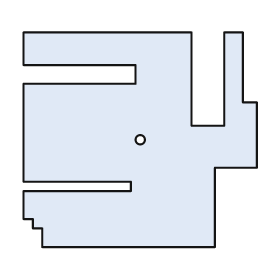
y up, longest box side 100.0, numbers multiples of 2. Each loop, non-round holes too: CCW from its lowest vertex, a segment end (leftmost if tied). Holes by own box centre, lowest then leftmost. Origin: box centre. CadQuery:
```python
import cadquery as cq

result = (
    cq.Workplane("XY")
    .moveTo(-42.0, -46.0)
    .lineTo(32.0, -46.0)
    .lineTo(32.0, -12.0)
    .lineTo(50.0, -12.0)
    .lineTo(50.0, 16.0)
    .lineTo(44.0, 16.0)
    .lineTo(44.0, 46.0)
    .lineTo(36.0, 46.0)
    .lineTo(36.0, 6.0)
    .lineTo(22.0, 6.0)
    .lineTo(22.0, 46.0)
    .lineTo(-50.0, 46.0)
    .lineTo(-50.0, 32.0)
    .lineTo(-2.0, 32.0)
    .lineTo(-2.0, 24.0)
    .lineTo(-50.0, 24.0)
    .lineTo(-50.0, -18.0)
    .lineTo(-4.0, -18.0)
    .lineTo(-4.0, -22.0)
    .lineTo(-50.0, -22.0)
    .lineTo(-50.0, -34.0)
    .lineTo(-46.0, -34.0)
    .lineTo(-46.0, -38.0)
    .lineTo(-42.0, -38.0)
    .close()
    .moveTo(0.0, 0.0)
    .circle(2.0)
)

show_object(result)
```